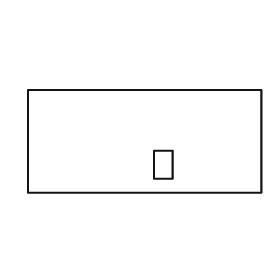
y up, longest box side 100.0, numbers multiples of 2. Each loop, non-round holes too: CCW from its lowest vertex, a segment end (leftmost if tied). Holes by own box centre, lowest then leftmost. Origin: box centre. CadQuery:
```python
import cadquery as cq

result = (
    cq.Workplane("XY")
    .moveTo(-50.0, -22.0)
    .lineTo(50.0, -22.0)
    .lineTo(50.0, 22.0)
    .lineTo(-50.0, 22.0)
    .close()
    .moveTo(4.0, -16.0)
    .lineTo(12.0, -16.0)
    .lineTo(12.0, -4.0)
    .lineTo(4.0, -4.0)
    .close()
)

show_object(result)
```